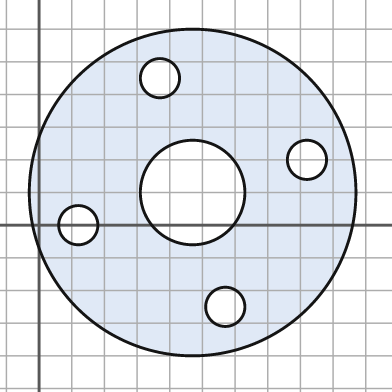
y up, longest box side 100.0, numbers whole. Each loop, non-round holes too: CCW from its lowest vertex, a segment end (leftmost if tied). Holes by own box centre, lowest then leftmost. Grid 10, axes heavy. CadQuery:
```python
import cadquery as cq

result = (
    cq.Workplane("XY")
    .moveTo(47.0, 10.0)
    .circle(50.0)
    .moveTo(57.0, -25.0)
    .circle(6.0)
    .moveTo(12.0, 0.0)
    .circle(6.0)
    .moveTo(47.0, 10.0)
    .circle(16.0)
    .moveTo(82.0, 20.0)
    .circle(6.0)
    .moveTo(37.0, 45.0)
    .circle(6.0)
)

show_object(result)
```